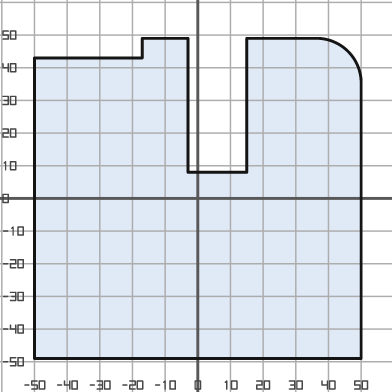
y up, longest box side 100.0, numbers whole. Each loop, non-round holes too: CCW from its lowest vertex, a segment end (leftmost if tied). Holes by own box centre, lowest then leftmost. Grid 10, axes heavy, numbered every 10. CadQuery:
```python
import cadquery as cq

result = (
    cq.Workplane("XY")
    .moveTo(-50.0, -49.0)
    .lineTo(50.0, -49.0)
    .lineTo(50.0, 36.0)
    .threePointArc((46.0, 45.0), (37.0, 49.0))
    .lineTo(15.0, 49.0)
    .lineTo(15.0, 8.0)
    .lineTo(-3.0, 8.0)
    .lineTo(-3.0, 49.0)
    .lineTo(-17.0, 49.0)
    .lineTo(-17.0, 43.0)
    .lineTo(-50.0, 43.0)
    .close()
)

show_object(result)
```